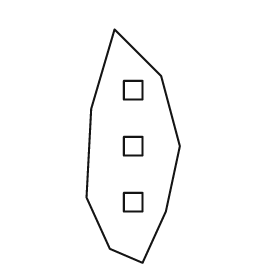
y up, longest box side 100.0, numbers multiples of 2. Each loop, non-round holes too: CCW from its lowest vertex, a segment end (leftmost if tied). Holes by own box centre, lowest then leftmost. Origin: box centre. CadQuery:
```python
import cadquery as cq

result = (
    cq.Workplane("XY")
    .moveTo(4.0, -50.0)
    .lineTo(14.0, -28.0)
    .lineTo(20.0, 0.0)
    .lineTo(12.0, 30.0)
    .lineTo(-8.0, 50.0)
    .lineTo(-18.0, 16.0)
    .lineTo(-20.0, -22.0)
    .lineTo(-10.0, -44.0)
    .close()
    .moveTo(-4.0, -28.0)
    .lineTo(4.0, -28.0)
    .lineTo(4.0, -20.0)
    .lineTo(-4.0, -20.0)
    .close()
    .moveTo(-4.0, -4.0)
    .lineTo(4.0, -4.0)
    .lineTo(4.0, 4.0)
    .lineTo(-4.0, 4.0)
    .close()
    .moveTo(-4.0, 20.0)
    .lineTo(4.0, 20.0)
    .lineTo(4.0, 28.0)
    .lineTo(-4.0, 28.0)
    .close()
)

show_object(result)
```